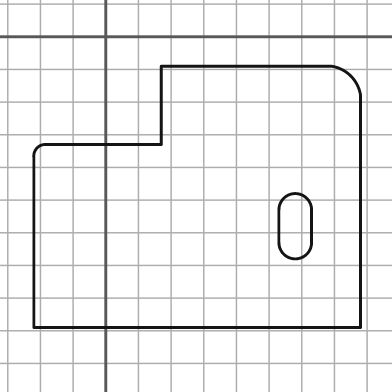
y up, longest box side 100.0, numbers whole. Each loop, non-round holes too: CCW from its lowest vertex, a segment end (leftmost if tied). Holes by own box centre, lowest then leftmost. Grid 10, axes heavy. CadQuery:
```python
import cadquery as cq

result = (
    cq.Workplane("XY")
    .moveTo(-22.0, -89.0)
    .lineTo(78.0, -89.0)
    .lineTo(78.0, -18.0)
    .threePointArc((75.0, -12.0), (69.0, -9.0))
    .lineTo(17.0, -9.0)
    .lineTo(17.0, -33.0)
    .lineTo(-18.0, -33.0)
    .threePointArc((-21.0, -34.0), (-22.0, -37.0))
    .close()
    .moveTo(53.0, -63.0)
    .threePointArc((58.0, -68.0), (63.0, -63.0))
    .lineTo(63.0, -53.0)
    .threePointArc((58.0, -48.0), (53.0, -53.0))
    .close()
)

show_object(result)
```